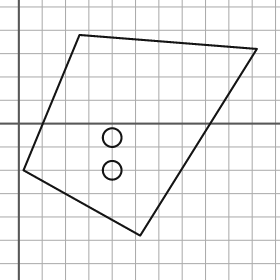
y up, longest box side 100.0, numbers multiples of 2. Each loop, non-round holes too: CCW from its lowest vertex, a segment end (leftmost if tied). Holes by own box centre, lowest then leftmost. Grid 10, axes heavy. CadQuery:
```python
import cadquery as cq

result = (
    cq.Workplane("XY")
    .moveTo(52.0, -48.0)
    .lineTo(102.0, 32.0)
    .lineTo(26.0, 38.0)
    .lineTo(2.0, -20.0)
    .close()
    .moveTo(40.0, -20.0)
    .circle(4.0)
    .moveTo(40.0, -6.0)
    .circle(4.0)
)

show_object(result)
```